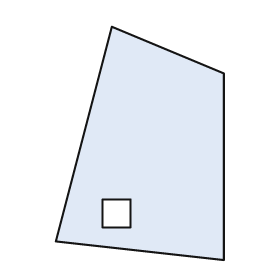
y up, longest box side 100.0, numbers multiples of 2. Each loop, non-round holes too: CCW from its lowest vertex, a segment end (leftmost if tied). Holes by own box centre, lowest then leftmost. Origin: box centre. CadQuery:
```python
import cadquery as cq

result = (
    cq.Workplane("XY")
    .moveTo(36.0, -50.0)
    .lineTo(36.0, 30.0)
    .lineTo(-12.0, 50.0)
    .lineTo(-36.0, -42.0)
    .close()
    .moveTo(-16.0, -36.0)
    .lineTo(-4.0, -36.0)
    .lineTo(-4.0, -24.0)
    .lineTo(-16.0, -24.0)
    .close()
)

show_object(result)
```